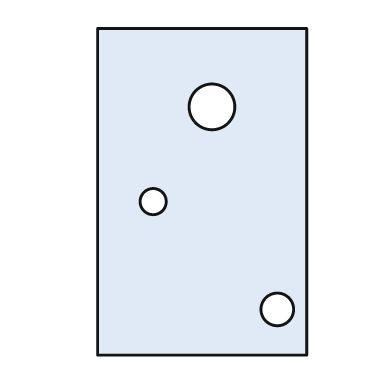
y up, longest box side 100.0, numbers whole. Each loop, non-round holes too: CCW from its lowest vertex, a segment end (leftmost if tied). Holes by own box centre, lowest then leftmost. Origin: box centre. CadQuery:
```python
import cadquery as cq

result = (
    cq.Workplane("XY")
    .moveTo(-32.0, -50.0)
    .lineTo(32.0, -50.0)
    .lineTo(32.0, 50.0)
    .lineTo(-32.0, 50.0)
    .close()
    .moveTo(23.0, -36.0)
    .circle(5.0)
    .moveTo(-15.0, -3.0)
    .circle(4.0)
    .moveTo(3.0, 26.0)
    .circle(7.0)
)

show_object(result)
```